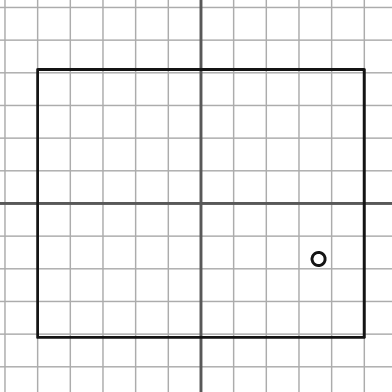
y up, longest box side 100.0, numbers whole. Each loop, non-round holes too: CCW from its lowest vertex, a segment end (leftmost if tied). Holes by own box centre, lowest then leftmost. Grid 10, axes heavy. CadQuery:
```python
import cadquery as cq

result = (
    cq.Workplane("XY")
    .moveTo(-50.0, -41.0)
    .lineTo(50.0, -41.0)
    .lineTo(50.0, 41.0)
    .lineTo(-50.0, 41.0)
    .close()
    .moveTo(36.0, -17.0)
    .circle(2.0)
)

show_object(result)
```